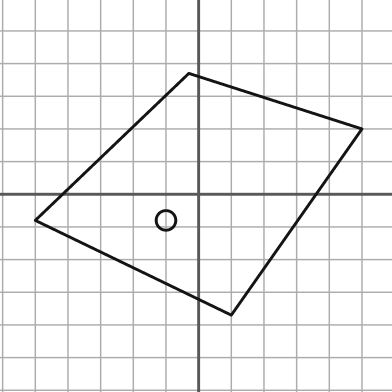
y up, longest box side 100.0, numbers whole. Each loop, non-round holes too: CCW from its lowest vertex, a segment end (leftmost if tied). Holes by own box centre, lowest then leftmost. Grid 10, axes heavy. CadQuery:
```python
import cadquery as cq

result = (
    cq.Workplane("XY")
    .moveTo(10.0, -37.0)
    .lineTo(50.0, 20.0)
    .lineTo(-3.0, 37.0)
    .lineTo(-50.0, -8.0)
    .close()
    .moveTo(-10.0, -8.0)
    .circle(3.0)
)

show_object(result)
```